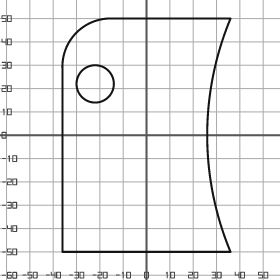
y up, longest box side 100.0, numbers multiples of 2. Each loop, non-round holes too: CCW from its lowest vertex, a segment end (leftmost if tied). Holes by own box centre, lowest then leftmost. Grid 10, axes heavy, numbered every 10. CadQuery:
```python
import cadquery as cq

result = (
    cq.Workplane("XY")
    .moveTo(-36.0, -50.0)
    .lineTo(36.0, -50.0)
    .threePointArc((26.0, 0.0), (36.0, 50.0))
    .lineTo(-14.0, 50.0)
    .threePointArc((-30.0, 44.0), (-36.0, 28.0))
    .close()
    .moveTo(-22.0, 22.0)
    .circle(8.0)
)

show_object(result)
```